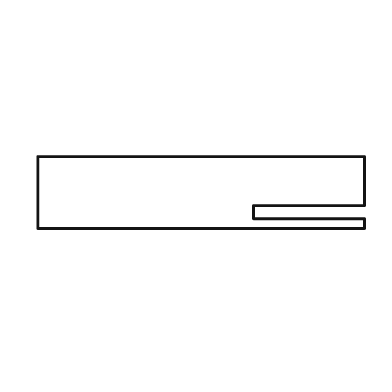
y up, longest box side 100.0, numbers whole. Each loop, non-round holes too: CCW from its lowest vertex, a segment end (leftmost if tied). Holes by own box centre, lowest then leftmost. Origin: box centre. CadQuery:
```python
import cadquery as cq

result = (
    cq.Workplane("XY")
    .moveTo(-50.0, -11.0)
    .lineTo(50.0, -11.0)
    .lineTo(50.0, -8.0)
    .lineTo(16.0, -8.0)
    .lineTo(16.0, -4.0)
    .lineTo(50.0, -4.0)
    .lineTo(50.0, 11.0)
    .lineTo(-50.0, 11.0)
    .close()
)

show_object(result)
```